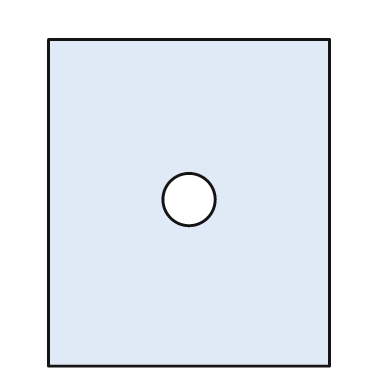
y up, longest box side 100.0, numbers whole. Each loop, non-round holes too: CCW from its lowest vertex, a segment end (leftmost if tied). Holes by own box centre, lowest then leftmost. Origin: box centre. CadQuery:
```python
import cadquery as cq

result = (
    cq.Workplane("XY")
    .moveTo(-43.0, -50.0)
    .lineTo(43.0, -50.0)
    .lineTo(43.0, 50.0)
    .lineTo(-43.0, 50.0)
    .close()
    .moveTo(0.0, 1.0)
    .circle(8.0)
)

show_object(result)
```